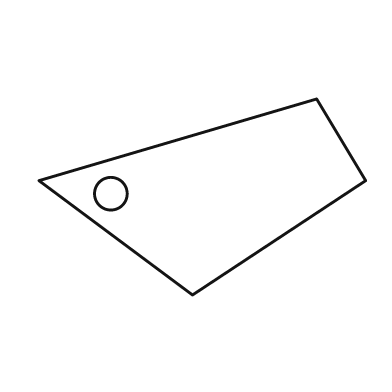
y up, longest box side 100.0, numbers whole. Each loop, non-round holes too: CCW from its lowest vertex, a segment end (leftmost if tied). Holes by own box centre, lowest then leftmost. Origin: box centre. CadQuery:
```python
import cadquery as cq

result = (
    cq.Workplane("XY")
    .moveTo(-3.0, -30.0)
    .lineTo(50.0, 5.0)
    .lineTo(35.0, 30.0)
    .lineTo(-50.0, 5.0)
    .close()
    .moveTo(-28.0, 1.0)
    .circle(5.0)
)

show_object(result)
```